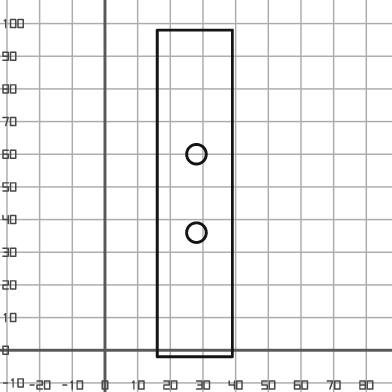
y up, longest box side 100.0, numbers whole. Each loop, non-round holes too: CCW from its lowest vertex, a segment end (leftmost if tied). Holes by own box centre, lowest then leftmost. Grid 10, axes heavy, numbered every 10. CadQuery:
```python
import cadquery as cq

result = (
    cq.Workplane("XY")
    .moveTo(16.0, -2.0)
    .lineTo(39.0, -2.0)
    .lineTo(39.0, 98.0)
    .lineTo(16.0, 98.0)
    .close()
    .moveTo(28.0, 36.0)
    .circle(3.0)
    .moveTo(28.0, 60.0)
    .circle(3.0)
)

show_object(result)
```